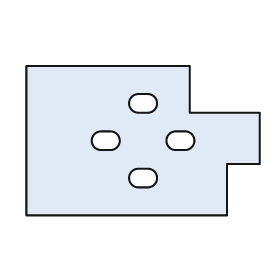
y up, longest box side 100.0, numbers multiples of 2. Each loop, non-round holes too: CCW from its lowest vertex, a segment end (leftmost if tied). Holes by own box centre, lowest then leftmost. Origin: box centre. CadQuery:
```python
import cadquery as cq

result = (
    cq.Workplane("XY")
    .moveTo(-50.0, -32.0)
    .lineTo(36.0, -32.0)
    .lineTo(36.0, -10.0)
    .lineTo(50.0, -10.0)
    .lineTo(50.0, 12.0)
    .lineTo(20.0, 12.0)
    .lineTo(20.0, 32.0)
    .lineTo(-50.0, 32.0)
    .close()
    .moveTo(-2.0, -20.0)
    .lineTo(2.0, -20.0)
    .threePointArc((6.0, -16.0), (2.0, -12.0))
    .lineTo(-2.0, -12.0)
    .threePointArc((-6.0, -16.0), (-2.0, -20.0))
    .close()
    .moveTo(-18.0, -4.0)
    .lineTo(-14.0, -4.0)
    .threePointArc((-10.0, 0.0), (-14.0, 4.0))
    .lineTo(-18.0, 4.0)
    .threePointArc((-22.0, 0.0), (-18.0, -4.0))
    .close()
    .moveTo(14.0, -4.0)
    .lineTo(18.0, -4.0)
    .threePointArc((22.0, 0.0), (18.0, 4.0))
    .lineTo(14.0, 4.0)
    .threePointArc((10.0, 0.0), (14.0, -4.0))
    .close()
    .moveTo(-2.0, 12.0)
    .lineTo(2.0, 12.0)
    .threePointArc((6.0, 16.0), (2.0, 20.0))
    .lineTo(-2.0, 20.0)
    .threePointArc((-6.0, 16.0), (-2.0, 12.0))
    .close()
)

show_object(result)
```